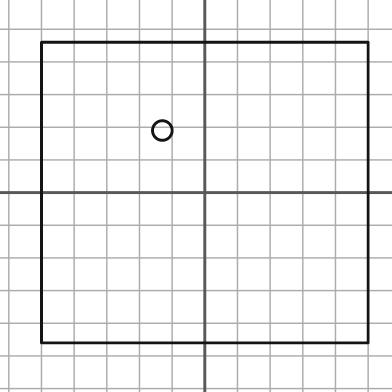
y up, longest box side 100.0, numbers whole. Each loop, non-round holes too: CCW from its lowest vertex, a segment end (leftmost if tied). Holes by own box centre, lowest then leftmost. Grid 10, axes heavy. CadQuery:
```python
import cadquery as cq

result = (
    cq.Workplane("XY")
    .moveTo(-50.0, -46.0)
    .lineTo(50.0, -46.0)
    .lineTo(50.0, 46.0)
    .lineTo(-50.0, 46.0)
    .close()
    .moveTo(-13.0, 19.0)
    .circle(3.0)
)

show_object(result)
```